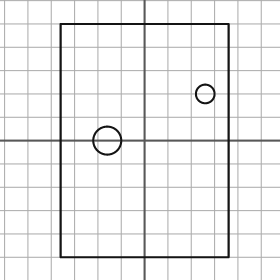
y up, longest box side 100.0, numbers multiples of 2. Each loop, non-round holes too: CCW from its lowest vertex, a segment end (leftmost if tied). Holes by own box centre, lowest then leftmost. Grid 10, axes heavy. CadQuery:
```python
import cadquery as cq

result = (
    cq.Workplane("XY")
    .moveTo(-36.0, -50.0)
    .lineTo(36.0, -50.0)
    .lineTo(36.0, 50.0)
    .lineTo(-36.0, 50.0)
    .close()
    .moveTo(-16.0, 0.0)
    .circle(6.0)
    .moveTo(26.0, 20.0)
    .circle(4.0)
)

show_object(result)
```